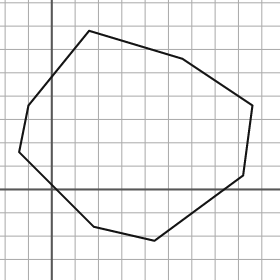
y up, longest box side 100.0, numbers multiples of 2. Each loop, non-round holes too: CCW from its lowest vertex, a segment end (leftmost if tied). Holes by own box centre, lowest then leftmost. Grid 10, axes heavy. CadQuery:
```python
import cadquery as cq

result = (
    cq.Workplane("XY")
    .moveTo(44.0, -22.0)
    .lineTo(82.0, 6.0)
    .lineTo(86.0, 36.0)
    .lineTo(56.0, 56.0)
    .lineTo(16.0, 68.0)
    .lineTo(-10.0, 36.0)
    .lineTo(-14.0, 16.0)
    .lineTo(18.0, -16.0)
    .close()
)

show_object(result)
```